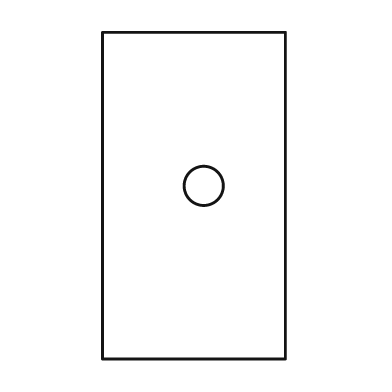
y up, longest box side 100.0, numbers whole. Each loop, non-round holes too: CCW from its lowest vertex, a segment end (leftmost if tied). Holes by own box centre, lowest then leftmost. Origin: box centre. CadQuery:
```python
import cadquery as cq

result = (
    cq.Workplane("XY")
    .moveTo(-28.0, -50.0)
    .lineTo(28.0, -50.0)
    .lineTo(28.0, 50.0)
    .lineTo(-28.0, 50.0)
    .close()
    .moveTo(3.0, 3.0)
    .circle(6.0)
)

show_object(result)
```